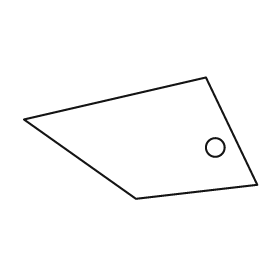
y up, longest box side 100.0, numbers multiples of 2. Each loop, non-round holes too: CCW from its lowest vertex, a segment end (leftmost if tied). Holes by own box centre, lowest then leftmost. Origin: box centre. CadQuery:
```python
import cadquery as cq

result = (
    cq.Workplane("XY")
    .moveTo(-2.0, -26.0)
    .lineTo(50.0, -20.0)
    .lineTo(28.0, 26.0)
    .lineTo(-50.0, 8.0)
    .close()
    .moveTo(32.0, -4.0)
    .circle(4.0)
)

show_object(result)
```